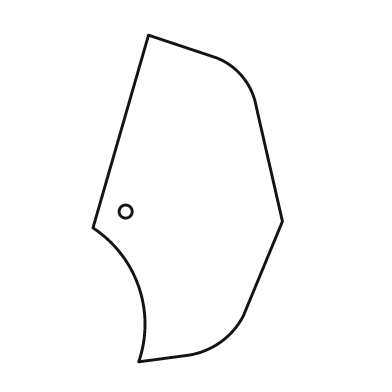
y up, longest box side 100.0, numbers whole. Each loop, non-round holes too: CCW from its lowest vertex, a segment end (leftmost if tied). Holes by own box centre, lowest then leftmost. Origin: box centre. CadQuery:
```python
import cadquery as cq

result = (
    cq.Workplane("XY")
    .moveTo(-15.0, -50.0)
    .lineTo(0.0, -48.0)
    .threePointArc((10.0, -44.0), (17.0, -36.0))
    .lineTo(29.0, -7.0)
    .lineTo(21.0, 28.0)
    .threePointArc((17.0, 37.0), (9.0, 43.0))
    .lineTo(-12.0, 50.0)
    .lineTo(-29.0, -9.0)
    .threePointArc((-15.0, -27.0), (-15.0, -50.0))
    .close()
    .moveTo(-19.0, -4.0)
    .circle(2.0)
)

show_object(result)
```